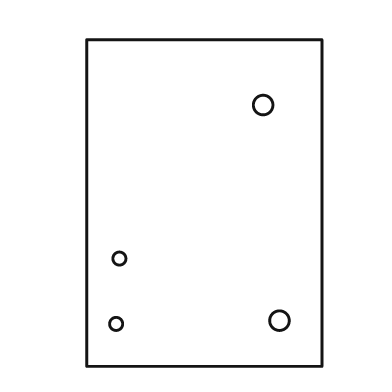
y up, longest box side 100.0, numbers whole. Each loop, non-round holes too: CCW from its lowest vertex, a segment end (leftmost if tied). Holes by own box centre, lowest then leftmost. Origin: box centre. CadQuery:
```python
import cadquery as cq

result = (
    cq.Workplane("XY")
    .moveTo(-36.0, -50.0)
    .lineTo(36.0, -50.0)
    .lineTo(36.0, 50.0)
    .lineTo(-36.0, 50.0)
    .close()
    .moveTo(-27.0, -37.0)
    .circle(2.0)
    .moveTo(23.0, -36.0)
    .circle(3.0)
    .moveTo(-26.0, -17.0)
    .circle(2.0)
    .moveTo(18.0, 30.0)
    .circle(3.0)
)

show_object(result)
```